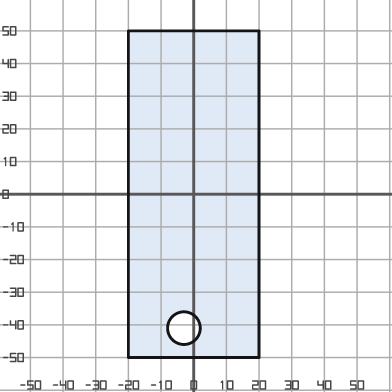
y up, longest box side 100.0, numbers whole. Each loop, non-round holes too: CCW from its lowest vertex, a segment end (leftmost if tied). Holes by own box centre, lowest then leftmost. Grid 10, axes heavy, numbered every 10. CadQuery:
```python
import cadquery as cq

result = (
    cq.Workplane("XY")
    .moveTo(-20.0, -50.0)
    .lineTo(20.0, -50.0)
    .lineTo(20.0, 50.0)
    .lineTo(-20.0, 50.0)
    .close()
    .moveTo(-3.0, -41.0)
    .circle(5.0)
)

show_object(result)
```